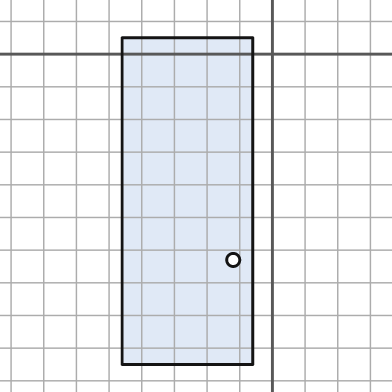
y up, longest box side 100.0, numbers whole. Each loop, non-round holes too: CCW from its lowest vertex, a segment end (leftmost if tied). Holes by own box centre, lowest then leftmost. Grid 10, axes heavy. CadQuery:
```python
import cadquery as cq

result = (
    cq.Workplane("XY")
    .moveTo(-46.0, -95.0)
    .lineTo(-6.0, -95.0)
    .lineTo(-6.0, 5.0)
    .lineTo(-46.0, 5.0)
    .close()
    .moveTo(-12.0, -63.0)
    .circle(2.0)
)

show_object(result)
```